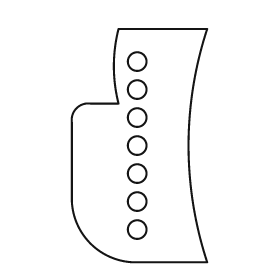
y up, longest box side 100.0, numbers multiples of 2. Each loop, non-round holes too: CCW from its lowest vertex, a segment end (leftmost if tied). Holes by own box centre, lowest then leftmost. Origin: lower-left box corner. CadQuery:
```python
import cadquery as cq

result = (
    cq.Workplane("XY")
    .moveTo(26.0, 0.0)
    .lineTo(58.0, 0.0)
    .threePointArc((50.0, 50.0), (58.0, 100.0))
    .lineTo(20.0, 100.0)
    .threePointArc((18.0, 84.0), (20.0, 68.0))
    .lineTo(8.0, 68.0)
    .threePointArc((2.0, 66.0), (0.0, 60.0))
    .lineTo(0.0, 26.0)
    .threePointArc((8.0, 8.0), (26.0, 0.0))
    .close()
    .moveTo(28.0, 14.0)
    .circle(4.0)
    .moveTo(28.0, 26.0)
    .circle(4.0)
    .moveTo(28.0, 38.0)
    .circle(4.0)
    .moveTo(28.0, 50.0)
    .circle(4.0)
    .moveTo(28.0, 62.0)
    .circle(4.0)
    .moveTo(28.0, 74.0)
    .circle(4.0)
    .moveTo(28.0, 86.0)
    .circle(4.0)
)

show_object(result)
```